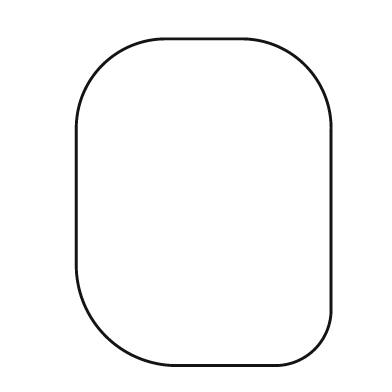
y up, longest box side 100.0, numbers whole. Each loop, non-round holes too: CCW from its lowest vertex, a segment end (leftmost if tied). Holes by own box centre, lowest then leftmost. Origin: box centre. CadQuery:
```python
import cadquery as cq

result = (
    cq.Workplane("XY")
    .moveTo(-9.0, -50.0)
    .lineTo(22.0, -50.0)
    .threePointArc((34.0, -45.0), (39.0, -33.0))
    .lineTo(39.0, 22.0)
    .threePointArc((31.0, 42.0), (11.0, 50.0))
    .lineTo(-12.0, 50.0)
    .threePointArc((-31.0, 42.0), (-39.0, 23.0))
    .lineTo(-39.0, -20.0)
    .threePointArc((-30.0, -41.0), (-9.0, -50.0))
    .close()
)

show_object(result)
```